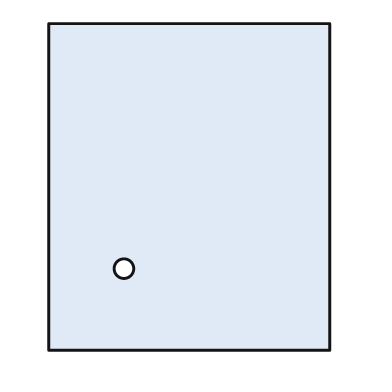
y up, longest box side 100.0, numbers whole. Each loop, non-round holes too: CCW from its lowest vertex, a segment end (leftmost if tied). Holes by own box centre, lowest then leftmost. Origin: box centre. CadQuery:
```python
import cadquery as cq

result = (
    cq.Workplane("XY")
    .moveTo(-43.0, -50.0)
    .lineTo(43.0, -50.0)
    .lineTo(43.0, 50.0)
    .lineTo(-43.0, 50.0)
    .close()
    .moveTo(-20.0, -25.0)
    .circle(3.0)
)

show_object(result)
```